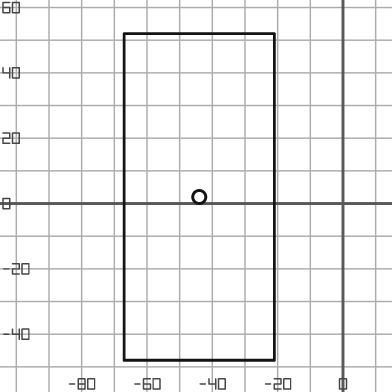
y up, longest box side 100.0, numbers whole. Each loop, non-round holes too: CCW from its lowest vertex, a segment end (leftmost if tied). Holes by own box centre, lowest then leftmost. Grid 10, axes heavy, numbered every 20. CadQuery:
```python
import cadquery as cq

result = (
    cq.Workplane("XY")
    .moveTo(-67.0, -48.0)
    .lineTo(-21.0, -48.0)
    .lineTo(-21.0, 52.0)
    .lineTo(-67.0, 52.0)
    .close()
    .moveTo(-44.0, 2.0)
    .circle(2.0)
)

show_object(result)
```